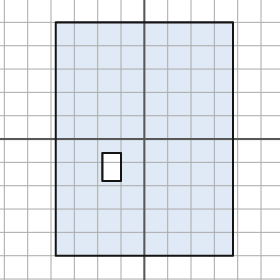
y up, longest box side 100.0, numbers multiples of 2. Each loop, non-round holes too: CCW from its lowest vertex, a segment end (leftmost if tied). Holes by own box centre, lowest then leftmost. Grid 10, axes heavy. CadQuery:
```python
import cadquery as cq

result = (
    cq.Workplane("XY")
    .moveTo(-38.0, -50.0)
    .lineTo(38.0, -50.0)
    .lineTo(38.0, 50.0)
    .lineTo(-38.0, 50.0)
    .close()
    .moveTo(-18.0, -18.0)
    .lineTo(-10.0, -18.0)
    .lineTo(-10.0, -6.0)
    .lineTo(-18.0, -6.0)
    .close()
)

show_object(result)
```